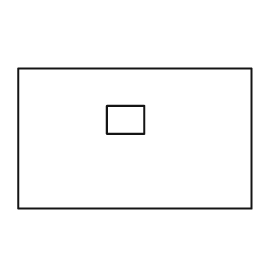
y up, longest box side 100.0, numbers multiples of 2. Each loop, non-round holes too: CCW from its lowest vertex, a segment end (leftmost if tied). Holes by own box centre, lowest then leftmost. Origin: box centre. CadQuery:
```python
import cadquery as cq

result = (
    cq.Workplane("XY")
    .moveTo(-50.0, -30.0)
    .lineTo(50.0, -30.0)
    .lineTo(50.0, 30.0)
    .lineTo(-50.0, 30.0)
    .close()
    .moveTo(-12.0, 2.0)
    .lineTo(4.0, 2.0)
    .lineTo(4.0, 14.0)
    .lineTo(-12.0, 14.0)
    .close()
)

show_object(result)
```